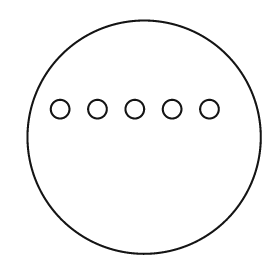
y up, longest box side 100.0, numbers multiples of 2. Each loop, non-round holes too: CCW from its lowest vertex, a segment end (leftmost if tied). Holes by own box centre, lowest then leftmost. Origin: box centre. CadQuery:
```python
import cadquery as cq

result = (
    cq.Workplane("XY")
    .moveTo(0.0, 0.0)
    .circle(50.0)
    .moveTo(-36.0, 12.0)
    .circle(4.0)
    .moveTo(-20.0, 12.0)
    .circle(4.0)
    .moveTo(-4.0, 12.0)
    .circle(4.0)
    .moveTo(12.0, 12.0)
    .circle(4.0)
    .moveTo(28.0, 12.0)
    .circle(4.0)
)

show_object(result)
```